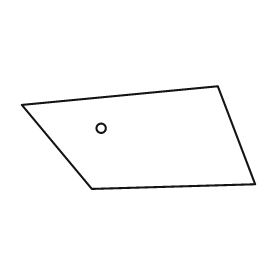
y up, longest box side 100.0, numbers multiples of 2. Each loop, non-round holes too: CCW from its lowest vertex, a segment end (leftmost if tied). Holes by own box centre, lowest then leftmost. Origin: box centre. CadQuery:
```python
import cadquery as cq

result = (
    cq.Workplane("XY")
    .moveTo(-20.0, -22.0)
    .lineTo(50.0, -20.0)
    .lineTo(34.0, 22.0)
    .lineTo(-50.0, 14.0)
    .close()
    .moveTo(-16.0, 4.0)
    .circle(2.0)
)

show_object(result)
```